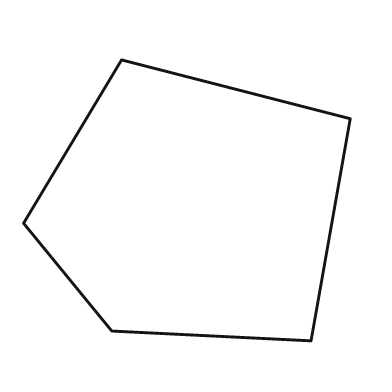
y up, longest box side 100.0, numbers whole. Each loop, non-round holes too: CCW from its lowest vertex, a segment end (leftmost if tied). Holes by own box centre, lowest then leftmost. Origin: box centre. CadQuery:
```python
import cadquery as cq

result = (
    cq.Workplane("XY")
    .moveTo(38.0, -43.0)
    .lineTo(50.0, 25.0)
    .lineTo(-20.0, 43.0)
    .lineTo(-50.0, -7.0)
    .lineTo(-23.0, -40.0)
    .close()
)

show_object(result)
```